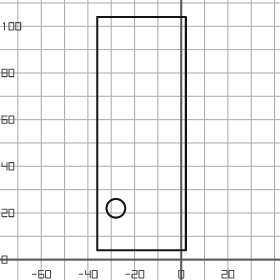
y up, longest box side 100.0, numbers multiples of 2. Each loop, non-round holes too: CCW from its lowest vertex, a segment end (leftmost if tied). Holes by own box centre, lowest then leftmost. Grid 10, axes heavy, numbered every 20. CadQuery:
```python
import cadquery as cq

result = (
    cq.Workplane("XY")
    .moveTo(-36.0, 4.0)
    .lineTo(2.0, 4.0)
    .lineTo(2.0, 104.0)
    .lineTo(-36.0, 104.0)
    .close()
    .moveTo(-28.0, 22.0)
    .circle(4.0)
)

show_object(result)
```